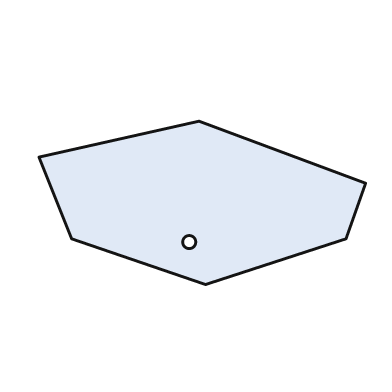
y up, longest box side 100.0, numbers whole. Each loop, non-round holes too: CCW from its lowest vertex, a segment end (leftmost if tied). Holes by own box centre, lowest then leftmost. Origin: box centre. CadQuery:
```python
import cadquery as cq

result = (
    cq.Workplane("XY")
    .moveTo(1.0, -25.0)
    .lineTo(44.0, -11.0)
    .lineTo(50.0, 6.0)
    .lineTo(-1.0, 25.0)
    .lineTo(-50.0, 14.0)
    .lineTo(-40.0, -11.0)
    .close()
    .moveTo(-4.0, -12.0)
    .circle(2.0)
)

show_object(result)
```